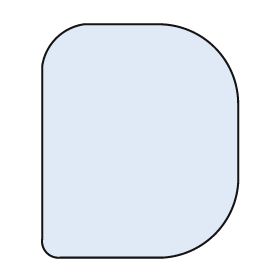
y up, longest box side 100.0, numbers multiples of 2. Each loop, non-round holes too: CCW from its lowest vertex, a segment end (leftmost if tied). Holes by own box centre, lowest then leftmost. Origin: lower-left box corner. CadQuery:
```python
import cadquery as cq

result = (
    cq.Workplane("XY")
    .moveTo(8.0, 0.0)
    .lineTo(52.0, 0.0)
    .threePointArc((74.0, 10.0), (84.0, 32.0))
    .lineTo(84.0, 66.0)
    .threePointArc((74.0, 90.0), (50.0, 100.0))
    .lineTo(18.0, 100.0)
    .threePointArc((6.0, 94.0), (0.0, 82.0))
    .lineTo(0.0, 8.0)
    .threePointArc((2.0, 2.0), (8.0, 0.0))
    .close()
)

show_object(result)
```